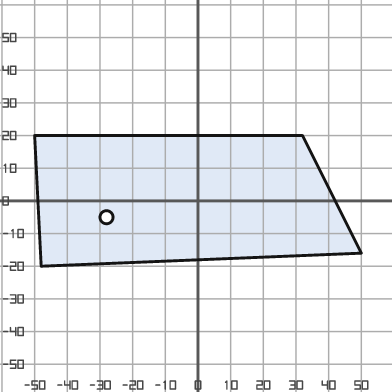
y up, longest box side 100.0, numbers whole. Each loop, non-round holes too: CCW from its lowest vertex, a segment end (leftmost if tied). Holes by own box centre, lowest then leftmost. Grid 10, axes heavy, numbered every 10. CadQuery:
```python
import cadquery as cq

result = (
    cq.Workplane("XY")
    .moveTo(-48.0, -20.0)
    .lineTo(50.0, -16.0)
    .lineTo(32.0, 20.0)
    .lineTo(-50.0, 20.0)
    .close()
    .moveTo(-28.0, -5.0)
    .circle(2.0)
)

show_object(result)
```